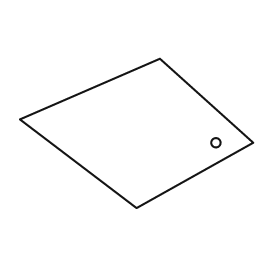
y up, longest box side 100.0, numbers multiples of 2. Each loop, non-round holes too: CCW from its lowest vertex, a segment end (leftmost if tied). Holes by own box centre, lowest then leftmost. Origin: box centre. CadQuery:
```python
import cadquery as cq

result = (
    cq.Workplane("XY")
    .moveTo(0.0, -32.0)
    .lineTo(50.0, -4.0)
    .lineTo(10.0, 32.0)
    .lineTo(-50.0, 6.0)
    .close()
    .moveTo(34.0, -4.0)
    .circle(2.0)
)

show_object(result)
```